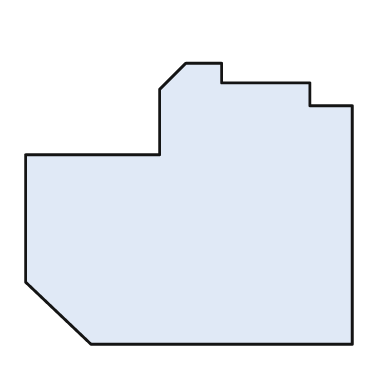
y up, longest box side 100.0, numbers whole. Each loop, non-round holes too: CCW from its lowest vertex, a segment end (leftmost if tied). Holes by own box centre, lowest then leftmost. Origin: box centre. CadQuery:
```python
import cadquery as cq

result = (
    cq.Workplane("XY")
    .moveTo(-30.0, -43.0)
    .lineTo(50.0, -43.0)
    .lineTo(50.0, 30.0)
    .lineTo(37.0, 30.0)
    .lineTo(37.0, 37.0)
    .lineTo(10.0, 37.0)
    .lineTo(10.0, 43.0)
    .lineTo(-1.0, 43.0)
    .lineTo(-9.0, 35.0)
    .lineTo(-9.0, 15.0)
    .lineTo(-50.0, 15.0)
    .lineTo(-50.0, -24.0)
    .close()
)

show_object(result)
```